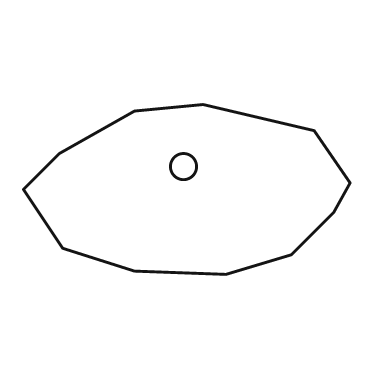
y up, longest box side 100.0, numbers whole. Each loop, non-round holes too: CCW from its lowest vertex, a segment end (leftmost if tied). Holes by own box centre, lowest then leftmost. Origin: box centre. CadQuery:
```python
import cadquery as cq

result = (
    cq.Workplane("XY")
    .moveTo(12.0, -26.0)
    .lineTo(32.0, -20.0)
    .lineTo(45.0, -7.0)
    .lineTo(50.0, 2.0)
    .lineTo(39.0, 18.0)
    .lineTo(5.0, 26.0)
    .lineTo(-16.0, 24.0)
    .lineTo(-39.0, 11.0)
    .lineTo(-50.0, 0.0)
    .lineTo(-38.0, -18.0)
    .lineTo(-16.0, -25.0)
    .close()
    .moveTo(-1.0, 7.0)
    .circle(4.0)
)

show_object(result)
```